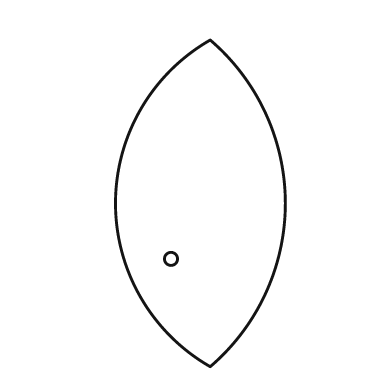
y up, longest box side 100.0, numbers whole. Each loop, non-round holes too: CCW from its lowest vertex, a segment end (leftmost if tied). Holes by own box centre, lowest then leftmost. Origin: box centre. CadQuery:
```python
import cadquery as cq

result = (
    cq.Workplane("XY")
    .moveTo(3.0, -50.0)
    .threePointArc((26.0, 0.0), (3.0, 50.0))
    .threePointArc((-26.0, 0.0), (3.0, -50.0))
    .close()
    .moveTo(-9.0, -17.0)
    .circle(2.0)
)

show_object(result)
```